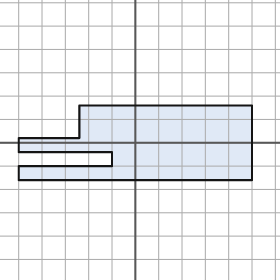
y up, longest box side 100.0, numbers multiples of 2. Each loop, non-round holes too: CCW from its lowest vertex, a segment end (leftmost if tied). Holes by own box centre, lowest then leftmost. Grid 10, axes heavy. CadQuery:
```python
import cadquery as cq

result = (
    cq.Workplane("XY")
    .moveTo(-50.0, -16.0)
    .lineTo(50.0, -16.0)
    .lineTo(50.0, 16.0)
    .lineTo(-24.0, 16.0)
    .lineTo(-24.0, 2.0)
    .lineTo(-50.0, 2.0)
    .lineTo(-50.0, -4.0)
    .lineTo(-10.0, -4.0)
    .lineTo(-10.0, -10.0)
    .lineTo(-50.0, -10.0)
    .close()
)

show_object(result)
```